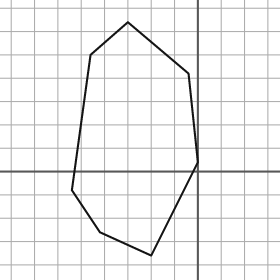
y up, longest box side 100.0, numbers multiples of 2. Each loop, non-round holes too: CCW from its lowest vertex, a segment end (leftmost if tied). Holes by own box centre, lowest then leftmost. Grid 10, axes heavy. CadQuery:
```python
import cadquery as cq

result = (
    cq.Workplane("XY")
    .moveTo(-20.0, -36.0)
    .lineTo(0.0, 4.0)
    .lineTo(-4.0, 42.0)
    .lineTo(-30.0, 64.0)
    .lineTo(-46.0, 50.0)
    .lineTo(-54.0, -8.0)
    .lineTo(-42.0, -26.0)
    .close()
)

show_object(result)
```